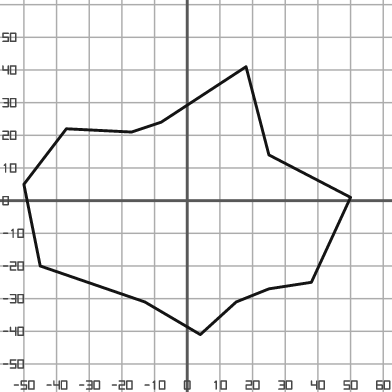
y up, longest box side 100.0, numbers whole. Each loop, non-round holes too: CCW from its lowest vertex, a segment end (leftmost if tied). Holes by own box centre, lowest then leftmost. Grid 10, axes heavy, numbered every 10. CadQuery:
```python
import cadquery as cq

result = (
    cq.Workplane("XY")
    .moveTo(4.0, -41.0)
    .lineTo(15.0, -31.0)
    .lineTo(25.0, -27.0)
    .lineTo(38.0, -25.0)
    .lineTo(50.0, 1.0)
    .lineTo(25.0, 14.0)
    .lineTo(18.0, 41.0)
    .lineTo(-8.0, 24.0)
    .lineTo(-17.0, 21.0)
    .lineTo(-37.0, 22.0)
    .lineTo(-50.0, 5.0)
    .lineTo(-45.0, -20.0)
    .lineTo(-13.0, -31.0)
    .close()
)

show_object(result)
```